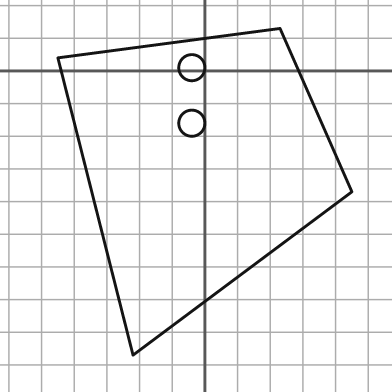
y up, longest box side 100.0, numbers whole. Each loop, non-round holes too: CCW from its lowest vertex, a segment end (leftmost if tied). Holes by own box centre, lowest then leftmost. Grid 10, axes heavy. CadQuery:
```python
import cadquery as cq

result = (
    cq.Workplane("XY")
    .moveTo(-22.0, -87.0)
    .lineTo(45.0, -37.0)
    .lineTo(23.0, 13.0)
    .lineTo(-45.0, 4.0)
    .close()
    .moveTo(-4.0, -16.0)
    .circle(4.0)
    .moveTo(-4.0, 1.0)
    .circle(4.0)
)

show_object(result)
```